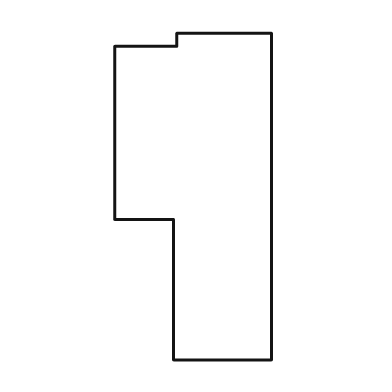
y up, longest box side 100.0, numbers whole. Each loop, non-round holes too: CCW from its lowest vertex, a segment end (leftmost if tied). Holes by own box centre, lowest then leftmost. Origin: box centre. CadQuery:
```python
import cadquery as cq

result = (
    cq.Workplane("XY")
    .moveTo(-6.0, -50.0)
    .lineTo(24.0, -50.0)
    .lineTo(24.0, 50.0)
    .lineTo(-5.0, 50.0)
    .lineTo(-5.0, 46.0)
    .lineTo(-24.0, 46.0)
    .lineTo(-24.0, -7.0)
    .lineTo(-6.0, -7.0)
    .close()
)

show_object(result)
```